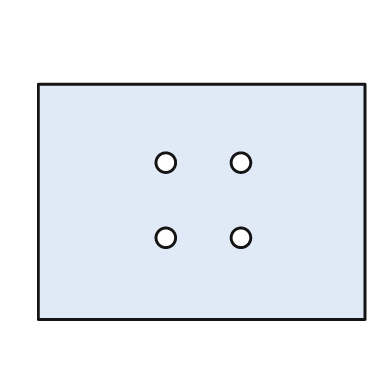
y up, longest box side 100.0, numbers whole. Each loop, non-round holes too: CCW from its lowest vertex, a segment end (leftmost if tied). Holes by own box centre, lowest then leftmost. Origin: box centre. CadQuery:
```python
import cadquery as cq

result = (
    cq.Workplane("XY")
    .moveTo(-50.0, -36.0)
    .lineTo(50.0, -36.0)
    .lineTo(50.0, 36.0)
    .lineTo(-50.0, 36.0)
    .close()
    .moveTo(-11.0, -11.0)
    .circle(3.0)
    .moveTo(12.0, -11.0)
    .circle(3.0)
    .moveTo(-11.0, 12.0)
    .circle(3.0)
    .moveTo(12.0, 12.0)
    .circle(3.0)
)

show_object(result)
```